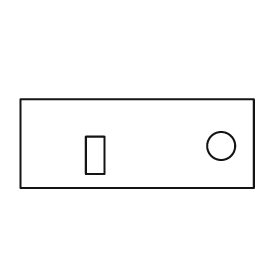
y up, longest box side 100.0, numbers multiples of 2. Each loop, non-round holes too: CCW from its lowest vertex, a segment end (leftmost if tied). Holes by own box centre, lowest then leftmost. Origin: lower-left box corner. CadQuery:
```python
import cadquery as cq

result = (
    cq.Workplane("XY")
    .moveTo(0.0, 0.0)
    .lineTo(100.0, 0.0)
    .lineTo(100.0, 38.0)
    .lineTo(0.0, 38.0)
    .close()
    .moveTo(28.0, 6.0)
    .lineTo(36.0, 6.0)
    .lineTo(36.0, 22.0)
    .lineTo(28.0, 22.0)
    .close()
    .moveTo(86.0, 18.0)
    .circle(6.0)
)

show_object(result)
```